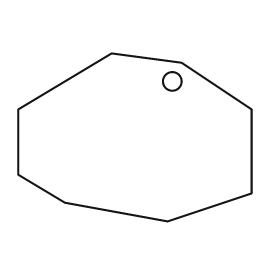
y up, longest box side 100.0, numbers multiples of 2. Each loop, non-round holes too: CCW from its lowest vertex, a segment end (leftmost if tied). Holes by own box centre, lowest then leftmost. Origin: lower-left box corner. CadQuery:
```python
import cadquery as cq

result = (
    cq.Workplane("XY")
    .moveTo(64.0, 0.0)
    .lineTo(100.0, 12.0)
    .lineTo(100.0, 48.0)
    .lineTo(70.0, 68.0)
    .lineTo(40.0, 72.0)
    .lineTo(0.0, 48.0)
    .lineTo(0.0, 20.0)
    .lineTo(20.0, 8.0)
    .close()
    .moveTo(66.0, 60.0)
    .circle(4.0)
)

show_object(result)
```